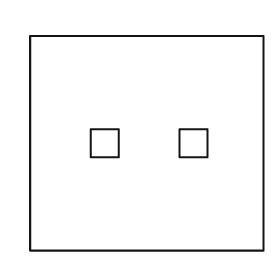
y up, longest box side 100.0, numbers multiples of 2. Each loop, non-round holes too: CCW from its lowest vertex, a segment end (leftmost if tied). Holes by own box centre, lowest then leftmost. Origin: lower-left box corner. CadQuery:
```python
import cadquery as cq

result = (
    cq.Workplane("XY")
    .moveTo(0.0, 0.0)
    .lineTo(100.0, 0.0)
    .lineTo(100.0, 92.0)
    .lineTo(0.0, 92.0)
    .close()
    .moveTo(26.0, 40.0)
    .lineTo(38.0, 40.0)
    .lineTo(38.0, 52.0)
    .lineTo(26.0, 52.0)
    .close()
    .moveTo(64.0, 40.0)
    .lineTo(76.0, 40.0)
    .lineTo(76.0, 52.0)
    .lineTo(64.0, 52.0)
    .close()
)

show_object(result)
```